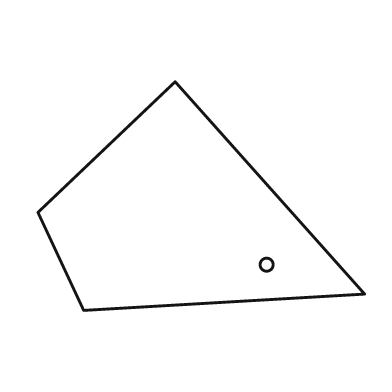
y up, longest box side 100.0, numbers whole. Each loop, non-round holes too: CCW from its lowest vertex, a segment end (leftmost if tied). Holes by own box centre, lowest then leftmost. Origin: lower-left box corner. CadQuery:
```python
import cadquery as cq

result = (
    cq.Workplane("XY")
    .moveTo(14.0, 0.0)
    .lineTo(100.0, 5.0)
    .lineTo(42.0, 70.0)
    .lineTo(0.0, 30.0)
    .close()
    .moveTo(70.0, 14.0)
    .circle(2.0)
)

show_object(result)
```